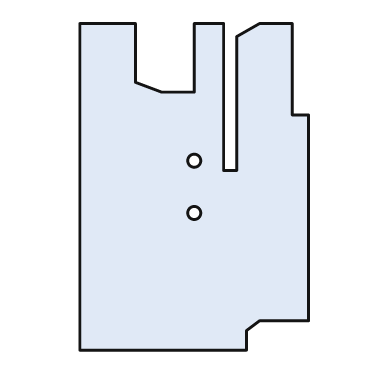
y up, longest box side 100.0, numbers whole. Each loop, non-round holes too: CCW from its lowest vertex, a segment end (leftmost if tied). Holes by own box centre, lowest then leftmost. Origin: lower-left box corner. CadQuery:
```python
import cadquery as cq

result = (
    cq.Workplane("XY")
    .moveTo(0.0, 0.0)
    .lineTo(51.0, 0.0)
    .lineTo(51.0, 6.0)
    .lineTo(55.0, 9.0)
    .lineTo(70.0, 9.0)
    .lineTo(70.0, 72.0)
    .lineTo(65.0, 72.0)
    .lineTo(65.0, 100.0)
    .lineTo(55.0, 100.0)
    .lineTo(48.0, 96.0)
    .lineTo(48.0, 55.0)
    .lineTo(44.0, 55.0)
    .lineTo(44.0, 100.0)
    .lineTo(35.0, 100.0)
    .lineTo(35.0, 79.0)
    .lineTo(25.0, 79.0)
    .lineTo(17.0, 82.0)
    .lineTo(17.0, 100.0)
    .lineTo(0.0, 100.0)
    .close()
    .moveTo(35.0, 42.0)
    .circle(2.0)
    .moveTo(35.0, 58.0)
    .circle(2.0)
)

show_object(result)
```